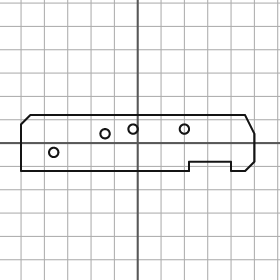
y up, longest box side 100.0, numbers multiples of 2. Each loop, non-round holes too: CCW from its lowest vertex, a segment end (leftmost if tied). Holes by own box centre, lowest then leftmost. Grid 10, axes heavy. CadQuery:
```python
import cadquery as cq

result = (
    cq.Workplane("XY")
    .moveTo(-50.0, -12.0)
    .lineTo(22.0, -12.0)
    .lineTo(22.0, -8.0)
    .lineTo(40.0, -8.0)
    .lineTo(40.0, -12.0)
    .lineTo(46.0, -12.0)
    .lineTo(50.0, -8.0)
    .lineTo(50.0, 4.0)
    .lineTo(46.0, 12.0)
    .lineTo(-46.0, 12.0)
    .lineTo(-50.0, 8.0)
    .close()
    .moveTo(-36.0, -4.0)
    .circle(2.0)
    .moveTo(-14.0, 4.0)
    .circle(2.0)
    .moveTo(-2.0, 6.0)
    .circle(2.0)
    .moveTo(20.0, 6.0)
    .circle(2.0)
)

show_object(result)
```